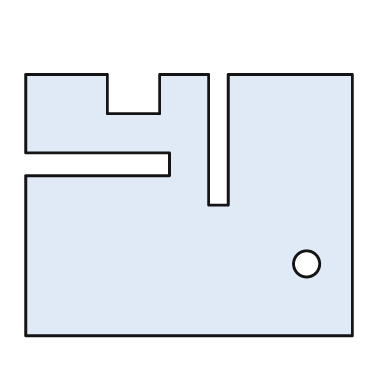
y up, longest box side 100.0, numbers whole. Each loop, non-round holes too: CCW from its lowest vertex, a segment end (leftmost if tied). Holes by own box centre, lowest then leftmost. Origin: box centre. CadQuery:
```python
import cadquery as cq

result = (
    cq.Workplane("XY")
    .moveTo(-50.0, -40.0)
    .lineTo(50.0, -40.0)
    .lineTo(50.0, 40.0)
    .lineTo(12.0, 40.0)
    .lineTo(12.0, 0.0)
    .lineTo(6.0, 0.0)
    .lineTo(6.0, 40.0)
    .lineTo(-9.0, 40.0)
    .lineTo(-9.0, 28.0)
    .lineTo(-25.0, 28.0)
    .lineTo(-25.0, 40.0)
    .lineTo(-50.0, 40.0)
    .lineTo(-50.0, 16.0)
    .lineTo(-6.0, 16.0)
    .lineTo(-6.0, 9.0)
    .lineTo(-50.0, 9.0)
    .close()
    .moveTo(36.0, -18.0)
    .circle(4.0)
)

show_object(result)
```